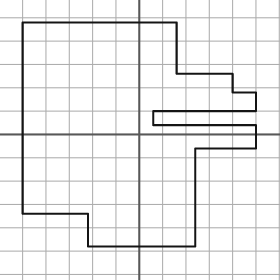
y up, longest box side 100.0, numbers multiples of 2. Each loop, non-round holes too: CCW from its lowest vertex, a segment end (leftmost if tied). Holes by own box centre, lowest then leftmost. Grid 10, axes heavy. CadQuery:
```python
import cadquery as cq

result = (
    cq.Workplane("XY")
    .moveTo(-22.0, -48.0)
    .lineTo(24.0, -48.0)
    .lineTo(24.0, -6.0)
    .lineTo(50.0, -6.0)
    .lineTo(50.0, 4.0)
    .lineTo(6.0, 4.0)
    .lineTo(6.0, 10.0)
    .lineTo(50.0, 10.0)
    .lineTo(50.0, 18.0)
    .lineTo(40.0, 18.0)
    .lineTo(40.0, 26.0)
    .lineTo(16.0, 26.0)
    .lineTo(16.0, 48.0)
    .lineTo(-50.0, 48.0)
    .lineTo(-50.0, -34.0)
    .lineTo(-22.0, -34.0)
    .close()
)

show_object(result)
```